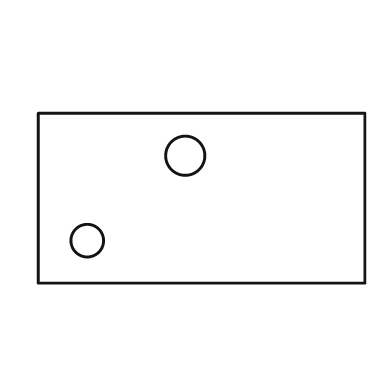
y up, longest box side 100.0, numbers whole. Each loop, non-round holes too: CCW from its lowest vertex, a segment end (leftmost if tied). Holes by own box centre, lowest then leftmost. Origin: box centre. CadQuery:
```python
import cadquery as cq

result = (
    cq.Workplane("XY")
    .moveTo(-50.0, -26.0)
    .lineTo(50.0, -26.0)
    .lineTo(50.0, 26.0)
    .lineTo(-50.0, 26.0)
    .close()
    .moveTo(-35.0, -13.0)
    .circle(5.0)
    .moveTo(-5.0, 13.0)
    .circle(6.0)
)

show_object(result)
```